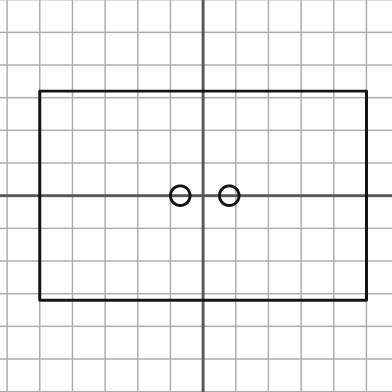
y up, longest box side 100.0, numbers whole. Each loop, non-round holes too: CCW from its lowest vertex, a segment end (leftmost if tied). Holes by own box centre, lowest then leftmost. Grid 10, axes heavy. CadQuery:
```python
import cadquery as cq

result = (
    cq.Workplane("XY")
    .moveTo(-50.0, -32.0)
    .lineTo(50.0, -32.0)
    .lineTo(50.0, 32.0)
    .lineTo(-50.0, 32.0)
    .close()
    .moveTo(-7.0, 0.0)
    .circle(3.0)
    .moveTo(8.0, 0.0)
    .circle(3.0)
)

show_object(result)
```